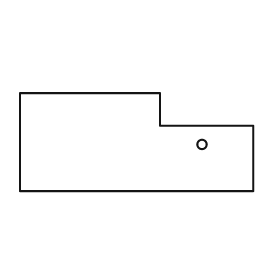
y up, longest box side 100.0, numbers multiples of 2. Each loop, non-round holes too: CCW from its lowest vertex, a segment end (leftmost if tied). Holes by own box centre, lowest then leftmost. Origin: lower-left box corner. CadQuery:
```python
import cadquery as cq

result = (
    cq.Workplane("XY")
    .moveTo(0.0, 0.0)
    .lineTo(100.0, 0.0)
    .lineTo(100.0, 28.0)
    .lineTo(60.0, 28.0)
    .lineTo(60.0, 42.0)
    .lineTo(0.0, 42.0)
    .close()
    .moveTo(78.0, 20.0)
    .circle(2.0)
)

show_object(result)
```